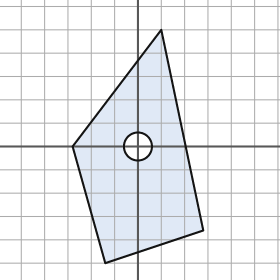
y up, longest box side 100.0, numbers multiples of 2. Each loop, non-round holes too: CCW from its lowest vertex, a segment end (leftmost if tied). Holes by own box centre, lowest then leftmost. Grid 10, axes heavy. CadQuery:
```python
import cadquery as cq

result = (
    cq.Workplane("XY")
    .moveTo(-14.0, -50.0)
    .lineTo(28.0, -36.0)
    .lineTo(10.0, 50.0)
    .lineTo(-28.0, 0.0)
    .close()
    .moveTo(0.0, 0.0)
    .circle(6.0)
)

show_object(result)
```